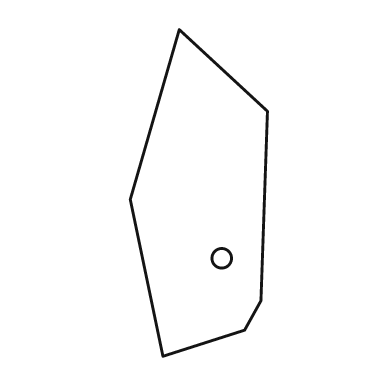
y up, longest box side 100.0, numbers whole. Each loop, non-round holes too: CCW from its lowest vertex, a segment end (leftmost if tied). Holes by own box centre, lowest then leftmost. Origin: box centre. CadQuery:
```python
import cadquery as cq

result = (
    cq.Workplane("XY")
    .moveTo(-11.0, -50.0)
    .lineTo(14.0, -42.0)
    .lineTo(19.0, -33.0)
    .lineTo(21.0, 25.0)
    .lineTo(-6.0, 50.0)
    .lineTo(-21.0, -2.0)
    .close()
    .moveTo(7.0, -20.0)
    .circle(3.0)
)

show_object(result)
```